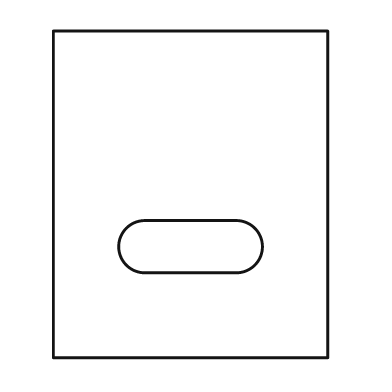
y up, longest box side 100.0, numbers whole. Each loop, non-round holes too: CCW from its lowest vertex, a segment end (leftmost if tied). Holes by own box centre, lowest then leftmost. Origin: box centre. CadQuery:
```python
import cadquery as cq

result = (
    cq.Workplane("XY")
    .moveTo(-42.0, -50.0)
    .lineTo(42.0, -50.0)
    .lineTo(42.0, 50.0)
    .lineTo(-42.0, 50.0)
    .close()
    .moveTo(-14.0, -24.0)
    .lineTo(14.0, -24.0)
    .threePointArc((22.0, -16.0), (14.0, -8.0))
    .lineTo(-14.0, -8.0)
    .threePointArc((-22.0, -16.0), (-14.0, -24.0))
    .close()
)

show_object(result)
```